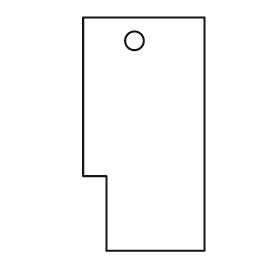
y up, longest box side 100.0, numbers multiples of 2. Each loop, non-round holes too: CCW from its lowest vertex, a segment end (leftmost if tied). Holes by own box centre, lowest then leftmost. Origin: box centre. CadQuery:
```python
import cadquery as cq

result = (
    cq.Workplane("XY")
    .moveTo(-16.0, -50.0)
    .lineTo(26.0, -50.0)
    .lineTo(26.0, 50.0)
    .lineTo(-26.0, 50.0)
    .lineTo(-26.0, -18.0)
    .lineTo(-16.0, -18.0)
    .close()
    .moveTo(-4.0, 40.0)
    .circle(4.0)
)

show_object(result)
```